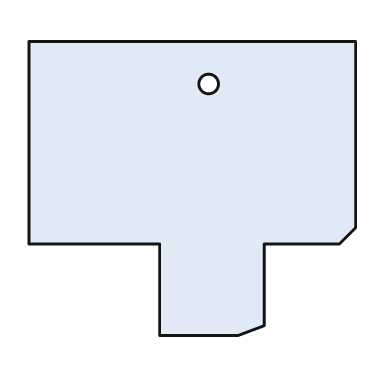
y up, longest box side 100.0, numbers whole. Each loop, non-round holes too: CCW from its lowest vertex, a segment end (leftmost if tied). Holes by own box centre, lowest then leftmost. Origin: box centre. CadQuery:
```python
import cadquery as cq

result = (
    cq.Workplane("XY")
    .moveTo(-10.0, -45.0)
    .lineTo(14.0, -45.0)
    .lineTo(22.0, -42.0)
    .lineTo(22.0, -17.0)
    .lineTo(45.0, -17.0)
    .lineTo(50.0, -12.0)
    .lineTo(50.0, 45.0)
    .lineTo(-50.0, 45.0)
    .lineTo(-50.0, -17.0)
    .lineTo(-10.0, -17.0)
    .close()
    .moveTo(5.0, 32.0)
    .circle(3.0)
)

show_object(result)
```